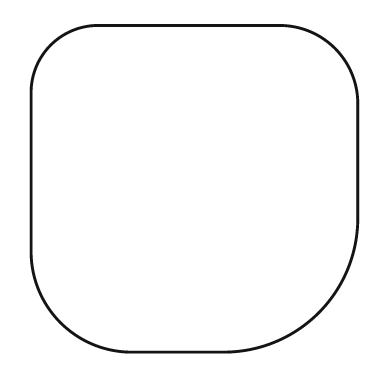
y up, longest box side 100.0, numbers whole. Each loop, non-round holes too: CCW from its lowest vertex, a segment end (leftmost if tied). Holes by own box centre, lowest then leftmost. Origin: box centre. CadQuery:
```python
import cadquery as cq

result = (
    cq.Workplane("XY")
    .moveTo(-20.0, -50.0)
    .lineTo(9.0, -50.0)
    .threePointArc((38.0, -38.0), (50.0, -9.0))
    .lineTo(50.0, 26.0)
    .threePointArc((43.0, 43.0), (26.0, 50.0))
    .lineTo(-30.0, 50.0)
    .threePointArc((-44.0, 44.0), (-50.0, 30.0))
    .lineTo(-50.0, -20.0)
    .threePointArc((-41.0, -41.0), (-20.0, -50.0))
    .close()
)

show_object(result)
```